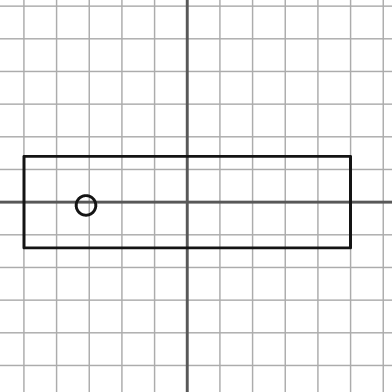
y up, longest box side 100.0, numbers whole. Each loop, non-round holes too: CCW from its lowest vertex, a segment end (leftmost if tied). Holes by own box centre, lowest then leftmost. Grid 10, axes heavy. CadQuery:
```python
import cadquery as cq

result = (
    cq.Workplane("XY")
    .moveTo(-50.0, -14.0)
    .lineTo(50.0, -14.0)
    .lineTo(50.0, 14.0)
    .lineTo(-50.0, 14.0)
    .close()
    .moveTo(-31.0, -1.0)
    .circle(3.0)
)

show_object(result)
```